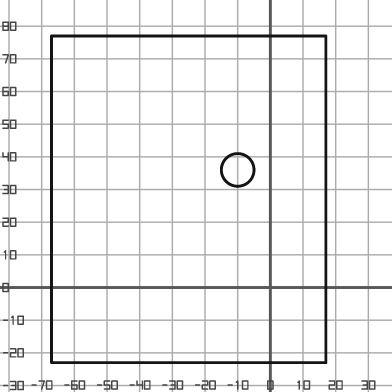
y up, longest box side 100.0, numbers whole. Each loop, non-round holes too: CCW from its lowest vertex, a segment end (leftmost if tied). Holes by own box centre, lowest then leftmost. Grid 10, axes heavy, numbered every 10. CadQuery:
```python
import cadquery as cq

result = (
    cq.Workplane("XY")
    .moveTo(-67.0, -23.0)
    .lineTo(17.0, -23.0)
    .lineTo(17.0, 77.0)
    .lineTo(-67.0, 77.0)
    .close()
    .moveTo(-10.0, 36.0)
    .circle(5.0)
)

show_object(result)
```